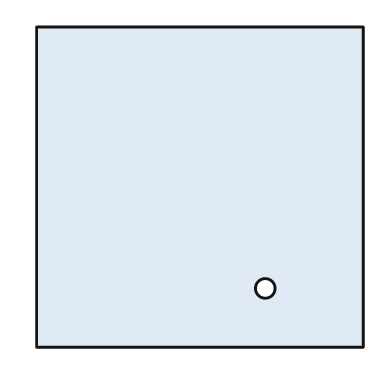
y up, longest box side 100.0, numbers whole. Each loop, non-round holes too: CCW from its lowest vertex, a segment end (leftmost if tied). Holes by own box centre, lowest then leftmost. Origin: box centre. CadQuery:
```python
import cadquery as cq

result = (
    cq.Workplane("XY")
    .moveTo(-50.0, -49.0)
    .lineTo(50.0, -49.0)
    .lineTo(50.0, 49.0)
    .lineTo(-50.0, 49.0)
    .close()
    .moveTo(20.0, -31.0)
    .circle(3.0)
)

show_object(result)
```